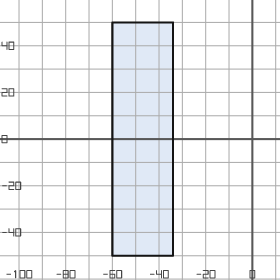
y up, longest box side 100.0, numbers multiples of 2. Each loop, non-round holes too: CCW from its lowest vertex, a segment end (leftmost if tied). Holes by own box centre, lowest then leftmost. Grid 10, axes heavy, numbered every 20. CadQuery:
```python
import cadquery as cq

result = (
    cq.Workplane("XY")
    .moveTo(-60.0, -50.0)
    .lineTo(-34.0, -50.0)
    .lineTo(-34.0, 50.0)
    .lineTo(-60.0, 50.0)
    .close()
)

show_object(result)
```